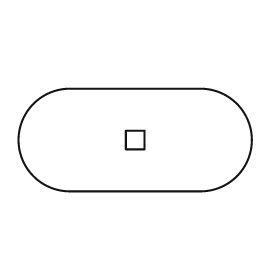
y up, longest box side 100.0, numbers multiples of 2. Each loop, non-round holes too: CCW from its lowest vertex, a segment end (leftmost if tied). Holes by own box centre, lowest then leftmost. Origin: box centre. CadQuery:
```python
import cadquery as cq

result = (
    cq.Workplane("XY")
    .moveTo(-28.0, -22.0)
    .lineTo(28.0, -22.0)
    .threePointArc((50.0, 0.0), (28.0, 22.0))
    .lineTo(-28.0, 22.0)
    .threePointArc((-50.0, 0.0), (-28.0, -22.0))
    .close()
    .moveTo(-4.0, -4.0)
    .lineTo(4.0, -4.0)
    .lineTo(4.0, 4.0)
    .lineTo(-4.0, 4.0)
    .close()
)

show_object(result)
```